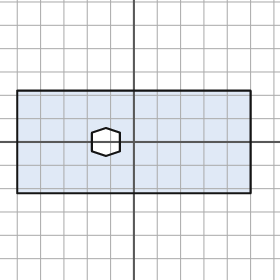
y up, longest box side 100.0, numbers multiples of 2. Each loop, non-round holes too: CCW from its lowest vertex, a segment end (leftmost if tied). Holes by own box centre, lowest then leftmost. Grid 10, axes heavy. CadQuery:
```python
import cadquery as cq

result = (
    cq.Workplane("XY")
    .moveTo(-50.0, -22.0)
    .lineTo(50.0, -22.0)
    .lineTo(50.0, 22.0)
    .lineTo(-50.0, 22.0)
    .close()
    .moveTo(-12.0, -6.0)
    .lineTo(-6.0, -4.0)
    .lineTo(-6.0, 4.0)
    .lineTo(-12.0, 6.0)
    .lineTo(-18.0, 4.0)
    .lineTo(-18.0, -4.0)
    .close()
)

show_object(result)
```